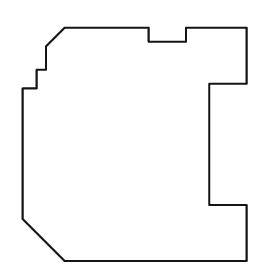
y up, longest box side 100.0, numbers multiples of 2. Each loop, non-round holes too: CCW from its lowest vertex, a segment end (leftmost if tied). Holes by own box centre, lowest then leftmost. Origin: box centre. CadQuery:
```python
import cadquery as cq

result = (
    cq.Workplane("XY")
    .moveTo(-30.0, -50.0)
    .lineTo(48.0, -50.0)
    .lineTo(48.0, -26.0)
    .lineTo(32.0, -26.0)
    .lineTo(32.0, 26.0)
    .lineTo(48.0, 26.0)
    .lineTo(48.0, 50.0)
    .lineTo(22.0, 50.0)
    .lineTo(22.0, 44.0)
    .lineTo(6.0, 44.0)
    .lineTo(6.0, 50.0)
    .lineTo(-30.0, 50.0)
    .lineTo(-38.0, 42.0)
    .lineTo(-38.0, 32.0)
    .lineTo(-42.0, 32.0)
    .lineTo(-42.0, 24.0)
    .lineTo(-48.0, 24.0)
    .lineTo(-48.0, -32.0)
    .close()
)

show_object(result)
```